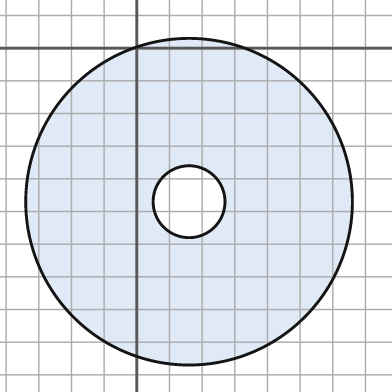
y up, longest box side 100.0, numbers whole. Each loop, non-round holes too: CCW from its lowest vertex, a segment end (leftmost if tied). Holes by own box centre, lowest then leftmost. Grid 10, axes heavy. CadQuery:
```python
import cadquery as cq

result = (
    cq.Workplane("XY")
    .moveTo(16.0, -47.0)
    .circle(50.0)
    .moveTo(16.0, -47.0)
    .circle(11.0)
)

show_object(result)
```